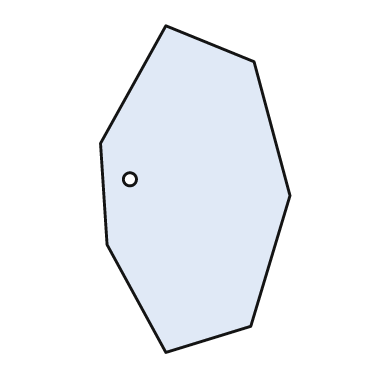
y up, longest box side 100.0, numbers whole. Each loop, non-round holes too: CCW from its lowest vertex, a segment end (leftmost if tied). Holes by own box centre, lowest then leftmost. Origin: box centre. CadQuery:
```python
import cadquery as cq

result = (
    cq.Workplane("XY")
    .moveTo(-9.0, -50.0)
    .lineTo(17.0, -42.0)
    .lineTo(29.0, -2.0)
    .lineTo(18.0, 39.0)
    .lineTo(-9.0, 50.0)
    .lineTo(-29.0, 14.0)
    .lineTo(-27.0, -17.0)
    .close()
    .moveTo(-20.0, 3.0)
    .circle(2.0)
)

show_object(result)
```